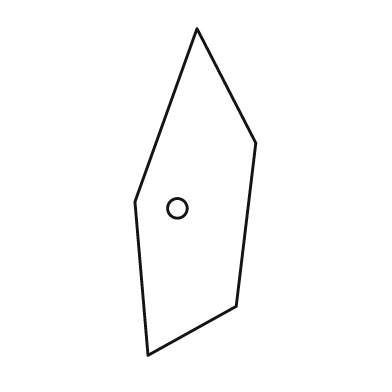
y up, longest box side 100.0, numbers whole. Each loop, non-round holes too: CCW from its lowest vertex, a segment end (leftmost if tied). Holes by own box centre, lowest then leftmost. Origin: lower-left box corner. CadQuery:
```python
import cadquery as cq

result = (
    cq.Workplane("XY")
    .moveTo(4.0, 0.0)
    .lineTo(31.0, 15.0)
    .lineTo(37.0, 65.0)
    .lineTo(19.0, 100.0)
    .lineTo(0.0, 47.0)
    .close()
    .moveTo(13.0, 45.0)
    .circle(3.0)
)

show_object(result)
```